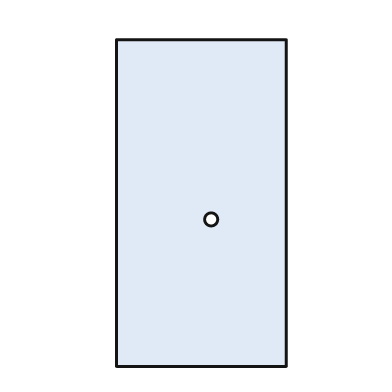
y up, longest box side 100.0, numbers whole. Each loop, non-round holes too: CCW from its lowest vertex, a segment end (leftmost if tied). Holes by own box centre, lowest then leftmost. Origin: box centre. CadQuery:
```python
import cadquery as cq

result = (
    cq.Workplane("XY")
    .moveTo(-26.0, -50.0)
    .lineTo(26.0, -50.0)
    .lineTo(26.0, 50.0)
    .lineTo(-26.0, 50.0)
    .close()
    .moveTo(3.0, -5.0)
    .circle(2.0)
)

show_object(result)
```